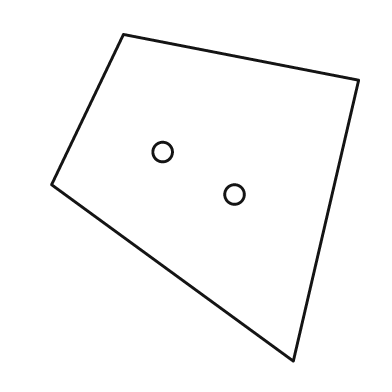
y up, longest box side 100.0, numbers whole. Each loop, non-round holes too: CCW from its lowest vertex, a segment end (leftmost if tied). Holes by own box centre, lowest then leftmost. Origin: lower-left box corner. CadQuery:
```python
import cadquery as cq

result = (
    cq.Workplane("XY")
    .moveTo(74.0, 0.0)
    .lineTo(94.0, 86.0)
    .lineTo(22.0, 100.0)
    .lineTo(0.0, 54.0)
    .close()
    .moveTo(56.0, 51.0)
    .circle(3.0)
    .moveTo(34.0, 64.0)
    .circle(3.0)
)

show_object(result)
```